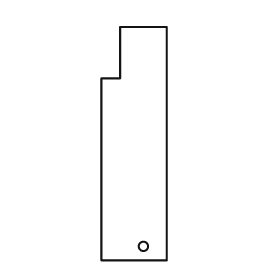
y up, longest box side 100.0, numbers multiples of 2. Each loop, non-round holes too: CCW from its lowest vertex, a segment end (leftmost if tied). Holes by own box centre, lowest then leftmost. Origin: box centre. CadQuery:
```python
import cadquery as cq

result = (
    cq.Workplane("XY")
    .moveTo(-14.0, -50.0)
    .lineTo(14.0, -50.0)
    .lineTo(14.0, 50.0)
    .lineTo(-6.0, 50.0)
    .lineTo(-6.0, 28.0)
    .lineTo(-14.0, 28.0)
    .close()
    .moveTo(4.0, -44.0)
    .circle(2.0)
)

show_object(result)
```